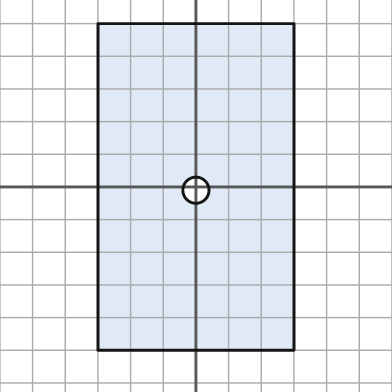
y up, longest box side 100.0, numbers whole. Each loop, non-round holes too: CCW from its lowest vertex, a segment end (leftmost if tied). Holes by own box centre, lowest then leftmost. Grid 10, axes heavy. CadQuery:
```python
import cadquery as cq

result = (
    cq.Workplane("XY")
    .moveTo(-30.0, -50.0)
    .lineTo(30.0, -50.0)
    .lineTo(30.0, 50.0)
    .lineTo(-30.0, 50.0)
    .close()
    .moveTo(0.0, -1.0)
    .circle(4.0)
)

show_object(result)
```